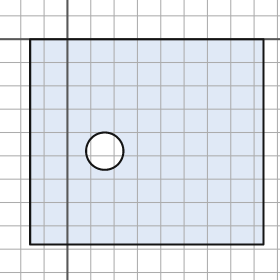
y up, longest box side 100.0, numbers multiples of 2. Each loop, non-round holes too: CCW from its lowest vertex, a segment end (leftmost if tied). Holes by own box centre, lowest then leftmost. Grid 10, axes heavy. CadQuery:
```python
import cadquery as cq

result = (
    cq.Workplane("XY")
    .moveTo(-16.0, -88.0)
    .lineTo(84.0, -88.0)
    .lineTo(84.0, 0.0)
    .lineTo(-16.0, 0.0)
    .close()
    .moveTo(16.0, -48.0)
    .circle(8.0)
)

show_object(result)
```